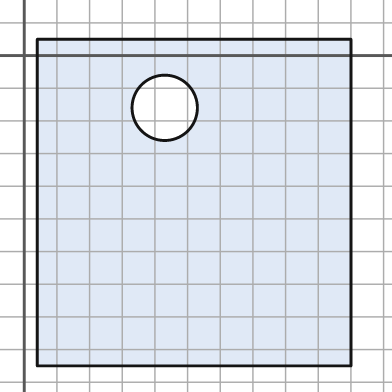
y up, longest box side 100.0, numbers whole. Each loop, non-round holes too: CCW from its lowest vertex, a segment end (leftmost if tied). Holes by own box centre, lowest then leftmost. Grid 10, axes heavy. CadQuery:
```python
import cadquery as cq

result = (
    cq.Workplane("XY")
    .moveTo(4.0, -95.0)
    .lineTo(100.0, -95.0)
    .lineTo(100.0, 5.0)
    .lineTo(4.0, 5.0)
    .close()
    .moveTo(43.0, -16.0)
    .circle(10.0)
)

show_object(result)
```